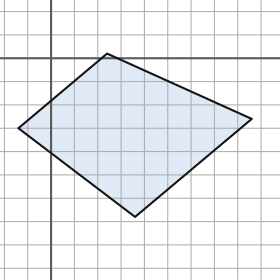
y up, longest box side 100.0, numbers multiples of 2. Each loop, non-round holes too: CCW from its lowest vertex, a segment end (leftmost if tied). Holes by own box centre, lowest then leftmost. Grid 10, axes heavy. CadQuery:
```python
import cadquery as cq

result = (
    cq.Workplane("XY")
    .moveTo(36.0, -68.0)
    .lineTo(86.0, -26.0)
    .lineTo(24.0, 2.0)
    .lineTo(-14.0, -30.0)
    .close()
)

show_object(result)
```